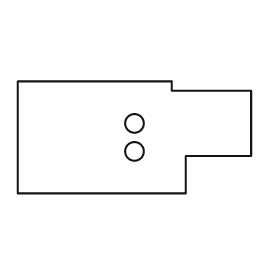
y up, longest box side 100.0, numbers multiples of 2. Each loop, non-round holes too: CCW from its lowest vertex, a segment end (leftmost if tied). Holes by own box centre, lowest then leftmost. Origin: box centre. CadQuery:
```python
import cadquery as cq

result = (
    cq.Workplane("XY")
    .moveTo(-50.0, -24.0)
    .lineTo(22.0, -24.0)
    .lineTo(22.0, -8.0)
    .lineTo(50.0, -8.0)
    .lineTo(50.0, 20.0)
    .lineTo(16.0, 20.0)
    .lineTo(16.0, 24.0)
    .lineTo(-50.0, 24.0)
    .close()
    .moveTo(0.0, -6.0)
    .circle(4.0)
    .moveTo(0.0, 6.0)
    .circle(4.0)
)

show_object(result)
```